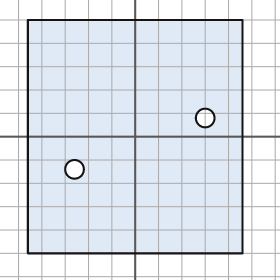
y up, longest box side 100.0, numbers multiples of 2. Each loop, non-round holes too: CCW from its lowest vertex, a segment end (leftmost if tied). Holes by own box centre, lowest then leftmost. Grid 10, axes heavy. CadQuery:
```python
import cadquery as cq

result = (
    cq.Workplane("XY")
    .moveTo(-46.0, -50.0)
    .lineTo(46.0, -50.0)
    .lineTo(46.0, 50.0)
    .lineTo(-46.0, 50.0)
    .close()
    .moveTo(-26.0, -14.0)
    .circle(4.0)
    .moveTo(30.0, 8.0)
    .circle(4.0)
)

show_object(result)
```